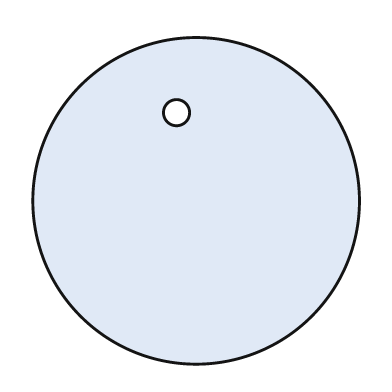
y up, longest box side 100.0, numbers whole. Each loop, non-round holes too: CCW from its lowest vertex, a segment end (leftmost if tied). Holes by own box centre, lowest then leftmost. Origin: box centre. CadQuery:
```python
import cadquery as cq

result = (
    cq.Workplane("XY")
    .moveTo(0.0, 0.0)
    .circle(50.0)
    .moveTo(-6.0, 27.0)
    .circle(4.0)
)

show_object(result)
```